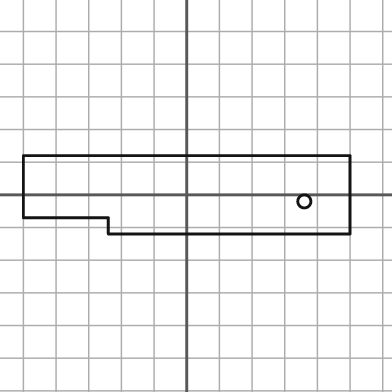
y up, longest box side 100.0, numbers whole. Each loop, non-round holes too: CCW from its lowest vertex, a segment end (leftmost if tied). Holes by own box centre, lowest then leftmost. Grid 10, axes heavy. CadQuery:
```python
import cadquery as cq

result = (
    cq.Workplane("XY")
    .moveTo(-24.0, -12.0)
    .lineTo(50.0, -12.0)
    .lineTo(50.0, 12.0)
    .lineTo(-50.0, 12.0)
    .lineTo(-50.0, -7.0)
    .lineTo(-24.0, -7.0)
    .close()
    .moveTo(36.0, -2.0)
    .circle(2.0)
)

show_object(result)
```